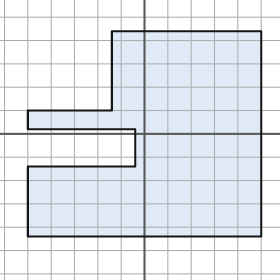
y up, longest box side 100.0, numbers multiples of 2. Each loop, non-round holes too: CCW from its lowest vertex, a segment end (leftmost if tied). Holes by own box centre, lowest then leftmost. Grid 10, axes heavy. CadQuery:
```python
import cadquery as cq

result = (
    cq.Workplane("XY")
    .moveTo(-50.0, -44.0)
    .lineTo(50.0, -44.0)
    .lineTo(50.0, 44.0)
    .lineTo(-14.0, 44.0)
    .lineTo(-14.0, 10.0)
    .lineTo(-50.0, 10.0)
    .lineTo(-50.0, 2.0)
    .lineTo(-4.0, 2.0)
    .lineTo(-4.0, -14.0)
    .lineTo(-50.0, -14.0)
    .close()
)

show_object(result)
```